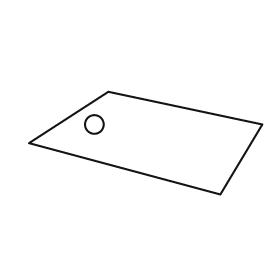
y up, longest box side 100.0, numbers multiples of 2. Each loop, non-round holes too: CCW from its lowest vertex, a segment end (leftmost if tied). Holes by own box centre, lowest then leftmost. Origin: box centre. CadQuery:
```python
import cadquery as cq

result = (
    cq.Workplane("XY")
    .moveTo(32.0, -22.0)
    .lineTo(50.0, 8.0)
    .lineTo(-16.0, 22.0)
    .lineTo(-50.0, 0.0)
    .close()
    .moveTo(-22.0, 8.0)
    .circle(4.0)
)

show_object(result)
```